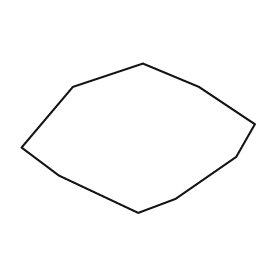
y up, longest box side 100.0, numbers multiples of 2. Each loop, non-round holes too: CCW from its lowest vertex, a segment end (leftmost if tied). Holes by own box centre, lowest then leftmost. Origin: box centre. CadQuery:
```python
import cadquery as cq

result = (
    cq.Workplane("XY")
    .moveTo(0.0, -32.0)
    .lineTo(16.0, -26.0)
    .lineTo(42.0, -8.0)
    .lineTo(50.0, 6.0)
    .lineTo(26.0, 22.0)
    .lineTo(2.0, 32.0)
    .lineTo(-28.0, 22.0)
    .lineTo(-50.0, -4.0)
    .lineTo(-34.0, -16.0)
    .close()
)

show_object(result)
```